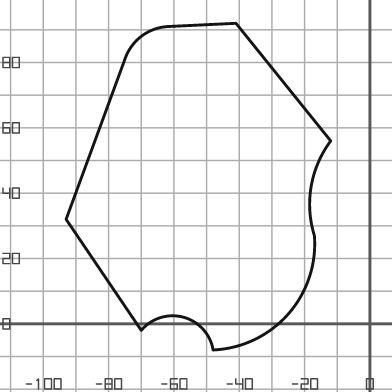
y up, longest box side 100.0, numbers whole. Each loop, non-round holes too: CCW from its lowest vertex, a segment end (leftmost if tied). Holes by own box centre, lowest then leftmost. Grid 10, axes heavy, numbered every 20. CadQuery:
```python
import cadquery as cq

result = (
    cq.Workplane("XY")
    .moveTo(-48.0, -8.0)
    .threePointArc((-25.0, 3.0), (-17.0, 27.0))
    .threePointArc((-18.0, 42.0), (-12.0, 56.0))
    .lineTo(-41.0, 92.0)
    .lineTo(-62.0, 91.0)
    .threePointArc((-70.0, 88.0), (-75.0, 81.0))
    .lineTo(-93.0, 32.0)
    .lineTo(-70.0, -2.0)
    .threePointArc((-57.0, 2.0), (-48.0, -8.0))
    .close()
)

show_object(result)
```